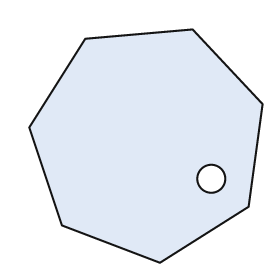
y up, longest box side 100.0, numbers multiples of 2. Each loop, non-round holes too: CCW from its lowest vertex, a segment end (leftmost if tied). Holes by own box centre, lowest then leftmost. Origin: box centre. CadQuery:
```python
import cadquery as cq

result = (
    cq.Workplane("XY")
    .moveTo(6.0, -50.0)
    .lineTo(44.0, -26.0)
    .lineTo(50.0, 18.0)
    .lineTo(20.0, 50.0)
    .lineTo(-26.0, 46.0)
    .lineTo(-50.0, 8.0)
    .lineTo(-36.0, -34.0)
    .close()
    .moveTo(28.0, -14.0)
    .circle(6.0)
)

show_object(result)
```